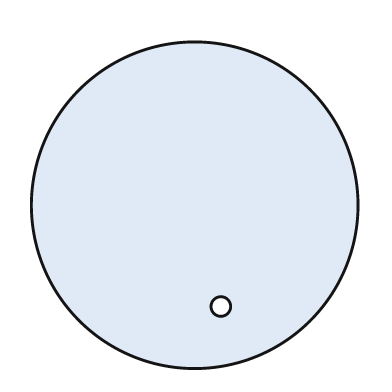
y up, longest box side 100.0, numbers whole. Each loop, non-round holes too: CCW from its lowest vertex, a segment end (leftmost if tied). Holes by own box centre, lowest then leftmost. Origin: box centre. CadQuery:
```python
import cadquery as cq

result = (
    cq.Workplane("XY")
    .moveTo(0.0, 0.0)
    .circle(50.0)
    .moveTo(8.0, -31.0)
    .circle(3.0)
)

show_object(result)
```